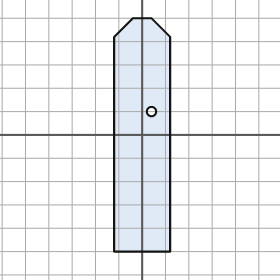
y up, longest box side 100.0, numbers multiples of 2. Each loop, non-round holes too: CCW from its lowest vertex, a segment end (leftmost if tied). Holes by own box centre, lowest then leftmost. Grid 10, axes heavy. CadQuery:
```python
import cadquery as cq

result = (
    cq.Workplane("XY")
    .moveTo(-12.0, -50.0)
    .lineTo(12.0, -50.0)
    .lineTo(12.0, 42.0)
    .lineTo(4.0, 50.0)
    .lineTo(-4.0, 50.0)
    .lineTo(-12.0, 42.0)
    .close()
    .moveTo(4.0, 10.0)
    .circle(2.0)
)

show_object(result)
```